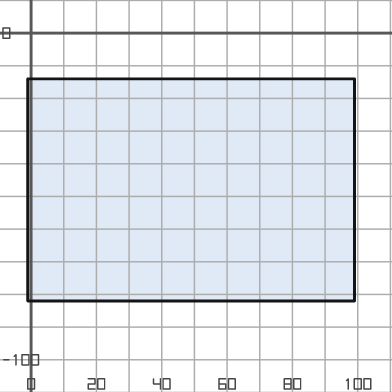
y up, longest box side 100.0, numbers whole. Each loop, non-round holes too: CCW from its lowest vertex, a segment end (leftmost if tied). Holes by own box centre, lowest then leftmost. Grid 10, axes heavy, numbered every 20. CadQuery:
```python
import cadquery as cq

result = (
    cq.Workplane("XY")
    .moveTo(-1.0, -82.0)
    .lineTo(99.0, -82.0)
    .lineTo(99.0, -14.0)
    .lineTo(-1.0, -14.0)
    .close()
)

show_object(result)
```